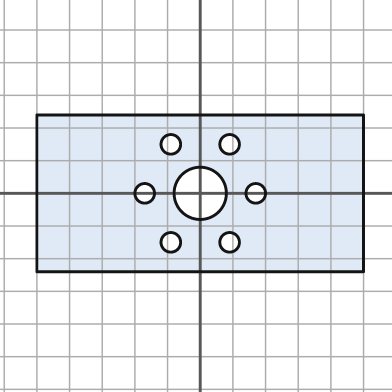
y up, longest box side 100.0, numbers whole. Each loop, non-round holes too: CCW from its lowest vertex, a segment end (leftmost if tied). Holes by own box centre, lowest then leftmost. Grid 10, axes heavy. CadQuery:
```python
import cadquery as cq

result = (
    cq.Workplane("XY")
    .moveTo(-50.0, -24.0)
    .lineTo(50.0, -24.0)
    .lineTo(50.0, 24.0)
    .lineTo(-50.0, 24.0)
    .close()
    .moveTo(-9.0, -15.0)
    .circle(3.0)
    .moveTo(9.0, -15.0)
    .circle(3.0)
    .moveTo(-17.0, 0.0)
    .circle(3.0)
    .moveTo(0.0, 0.0)
    .circle(8.0)
    .moveTo(17.0, 0.0)
    .circle(3.0)
    .moveTo(-9.0, 15.0)
    .circle(3.0)
    .moveTo(9.0, 15.0)
    .circle(3.0)
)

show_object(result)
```